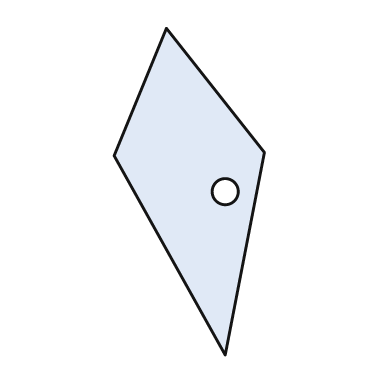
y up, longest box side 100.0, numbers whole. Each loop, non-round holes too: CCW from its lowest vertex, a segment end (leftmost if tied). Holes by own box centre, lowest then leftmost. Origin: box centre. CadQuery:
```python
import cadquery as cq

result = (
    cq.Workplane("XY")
    .moveTo(11.0, -50.0)
    .lineTo(23.0, 12.0)
    .lineTo(-7.0, 50.0)
    .lineTo(-23.0, 11.0)
    .close()
    .moveTo(11.0, 0.0)
    .circle(4.0)
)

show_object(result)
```